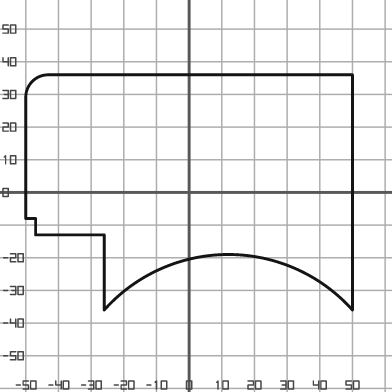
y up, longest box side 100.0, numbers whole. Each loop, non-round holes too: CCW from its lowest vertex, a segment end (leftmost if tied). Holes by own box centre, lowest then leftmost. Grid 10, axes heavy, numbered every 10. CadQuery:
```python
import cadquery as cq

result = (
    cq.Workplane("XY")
    .moveTo(-26.0, -36.0)
    .threePointArc((12.0, -19.0), (50.0, -36.0))
    .lineTo(50.0, 36.0)
    .lineTo(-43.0, 36.0)
    .threePointArc((-48.0, 34.0), (-50.0, 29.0))
    .lineTo(-50.0, -8.0)
    .lineTo(-47.0, -8.0)
    .lineTo(-47.0, -13.0)
    .lineTo(-26.0, -13.0)
    .close()
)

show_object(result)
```